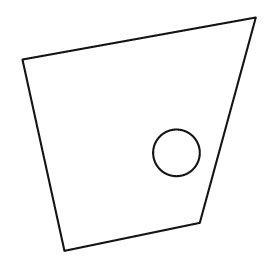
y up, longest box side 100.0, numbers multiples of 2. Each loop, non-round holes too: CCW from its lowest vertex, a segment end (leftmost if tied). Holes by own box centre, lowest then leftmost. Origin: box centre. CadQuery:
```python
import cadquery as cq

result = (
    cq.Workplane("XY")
    .moveTo(-32.0, -50.0)
    .lineTo(26.0, -38.0)
    .lineTo(50.0, 50.0)
    .lineTo(-50.0, 32.0)
    .close()
    .moveTo(16.0, -8.0)
    .circle(10.0)
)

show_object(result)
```